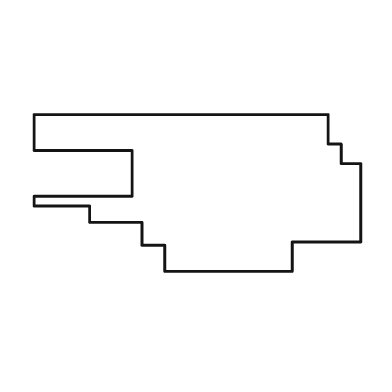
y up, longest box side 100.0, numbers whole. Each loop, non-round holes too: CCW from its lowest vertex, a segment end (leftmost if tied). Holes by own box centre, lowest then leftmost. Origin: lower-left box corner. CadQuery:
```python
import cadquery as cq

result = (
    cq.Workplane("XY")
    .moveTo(40.0, 0.0)
    .lineTo(79.0, 0.0)
    .lineTo(79.0, 9.0)
    .lineTo(100.0, 9.0)
    .lineTo(100.0, 33.0)
    .lineTo(94.0, 33.0)
    .lineTo(94.0, 39.0)
    .lineTo(90.0, 39.0)
    .lineTo(90.0, 48.0)
    .lineTo(0.0, 48.0)
    .lineTo(0.0, 37.0)
    .lineTo(30.0, 37.0)
    .lineTo(30.0, 23.0)
    .lineTo(0.0, 23.0)
    .lineTo(0.0, 20.0)
    .lineTo(17.0, 20.0)
    .lineTo(17.0, 15.0)
    .lineTo(33.0, 15.0)
    .lineTo(33.0, 8.0)
    .lineTo(40.0, 8.0)
    .close()
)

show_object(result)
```